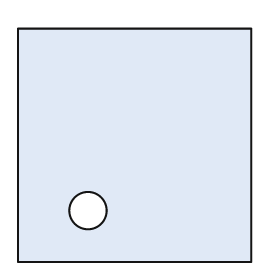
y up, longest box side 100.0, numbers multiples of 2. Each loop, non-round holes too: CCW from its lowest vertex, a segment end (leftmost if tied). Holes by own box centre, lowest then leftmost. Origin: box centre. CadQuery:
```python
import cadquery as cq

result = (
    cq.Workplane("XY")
    .moveTo(-50.0, -50.0)
    .lineTo(50.0, -50.0)
    .lineTo(50.0, 50.0)
    .lineTo(-50.0, 50.0)
    .close()
    .moveTo(-20.0, -28.0)
    .circle(8.0)
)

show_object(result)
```